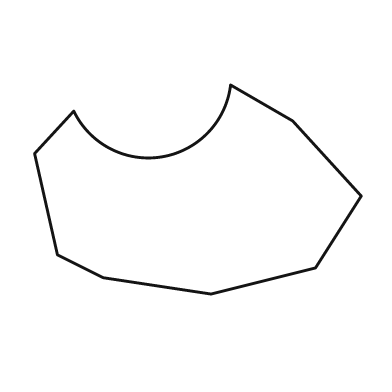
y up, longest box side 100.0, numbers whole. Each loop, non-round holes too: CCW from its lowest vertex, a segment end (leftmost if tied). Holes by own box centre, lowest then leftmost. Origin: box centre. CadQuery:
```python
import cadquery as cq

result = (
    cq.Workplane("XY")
    .moveTo(4.0, -32.0)
    .lineTo(36.0, -24.0)
    .lineTo(50.0, -2.0)
    .lineTo(29.0, 21.0)
    .lineTo(10.0, 32.0)
    .threePointArc((-11.0, 10.0), (-38.0, 24.0))
    .lineTo(-50.0, 11.0)
    .lineTo(-43.0, -20.0)
    .lineTo(-29.0, -27.0)
    .close()
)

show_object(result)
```